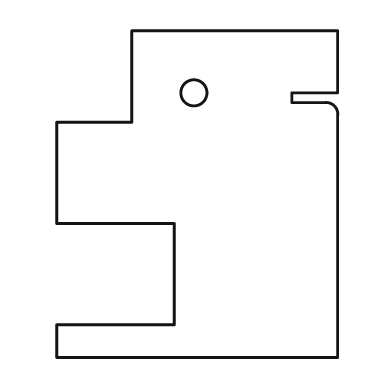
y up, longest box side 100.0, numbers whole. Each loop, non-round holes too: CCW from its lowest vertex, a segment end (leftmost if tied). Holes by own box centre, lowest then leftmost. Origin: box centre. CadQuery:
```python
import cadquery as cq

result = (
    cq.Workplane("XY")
    .moveTo(-43.0, -50.0)
    .lineTo(43.0, -50.0)
    .lineTo(43.0, 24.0)
    .threePointArc((42.0, 27.0), (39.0, 28.0))
    .lineTo(29.0, 28.0)
    .lineTo(29.0, 31.0)
    .lineTo(43.0, 31.0)
    .lineTo(43.0, 50.0)
    .lineTo(-20.0, 50.0)
    .lineTo(-20.0, 22.0)
    .lineTo(-43.0, 22.0)
    .lineTo(-43.0, -9.0)
    .lineTo(-7.0, -9.0)
    .lineTo(-7.0, -40.0)
    .lineTo(-43.0, -40.0)
    .close()
    .moveTo(-1.0, 31.0)
    .circle(4.0)
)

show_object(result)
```